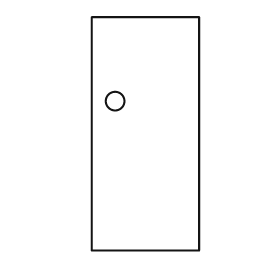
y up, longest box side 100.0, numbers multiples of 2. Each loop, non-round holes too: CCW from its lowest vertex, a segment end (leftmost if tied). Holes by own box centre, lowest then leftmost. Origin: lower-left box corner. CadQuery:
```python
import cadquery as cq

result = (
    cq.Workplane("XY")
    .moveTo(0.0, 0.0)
    .lineTo(46.0, 0.0)
    .lineTo(46.0, 100.0)
    .lineTo(0.0, 100.0)
    .close()
    .moveTo(10.0, 64.0)
    .circle(4.0)
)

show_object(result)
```